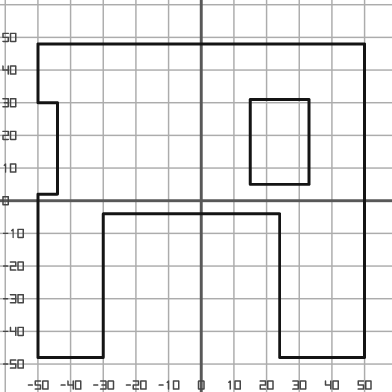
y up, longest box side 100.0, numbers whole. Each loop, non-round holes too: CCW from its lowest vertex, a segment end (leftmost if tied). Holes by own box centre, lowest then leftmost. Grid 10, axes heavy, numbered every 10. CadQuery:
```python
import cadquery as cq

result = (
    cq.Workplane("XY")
    .moveTo(-50.0, -48.0)
    .lineTo(-30.0, -48.0)
    .lineTo(-30.0, -4.0)
    .lineTo(24.0, -4.0)
    .lineTo(24.0, -48.0)
    .lineTo(50.0, -48.0)
    .lineTo(50.0, 48.0)
    .lineTo(-50.0, 48.0)
    .lineTo(-50.0, 30.0)
    .lineTo(-44.0, 30.0)
    .lineTo(-44.0, 2.0)
    .lineTo(-50.0, 2.0)
    .close()
    .moveTo(15.0, 5.0)
    .lineTo(33.0, 5.0)
    .lineTo(33.0, 31.0)
    .lineTo(15.0, 31.0)
    .close()
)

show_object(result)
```